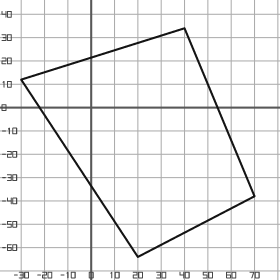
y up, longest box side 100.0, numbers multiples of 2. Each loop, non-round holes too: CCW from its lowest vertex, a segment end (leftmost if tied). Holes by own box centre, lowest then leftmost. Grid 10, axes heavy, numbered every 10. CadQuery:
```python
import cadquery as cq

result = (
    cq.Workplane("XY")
    .moveTo(20.0, -64.0)
    .lineTo(70.0, -38.0)
    .lineTo(40.0, 34.0)
    .lineTo(-30.0, 12.0)
    .close()
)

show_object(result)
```